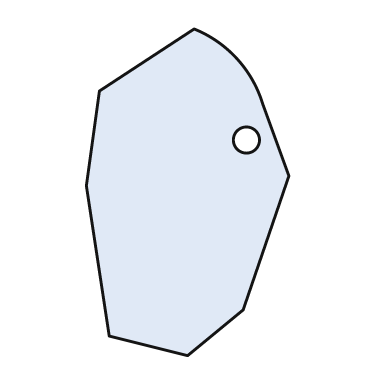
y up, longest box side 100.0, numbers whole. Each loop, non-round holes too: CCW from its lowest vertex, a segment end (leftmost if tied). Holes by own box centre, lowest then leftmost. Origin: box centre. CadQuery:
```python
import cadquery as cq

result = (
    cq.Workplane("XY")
    .moveTo(0.0, -50.0)
    .lineTo(17.0, -36.0)
    .lineTo(31.0, 5.0)
    .lineTo(23.0, 27.0)
    .threePointArc((15.0, 41.0), (2.0, 50.0))
    .lineTo(-27.0, 31.0)
    .lineTo(-31.0, 2.0)
    .lineTo(-24.0, -44.0)
    .close()
    .moveTo(18.0, 16.0)
    .circle(4.0)
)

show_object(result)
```